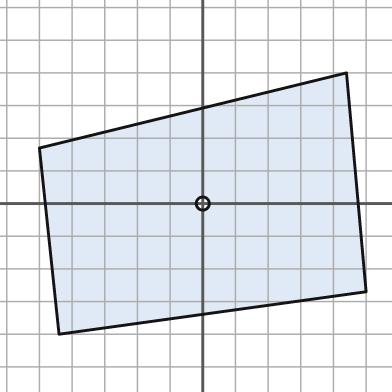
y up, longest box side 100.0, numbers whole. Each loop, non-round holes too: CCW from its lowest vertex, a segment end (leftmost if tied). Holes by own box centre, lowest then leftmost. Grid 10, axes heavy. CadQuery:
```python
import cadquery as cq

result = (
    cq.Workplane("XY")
    .moveTo(-44.0, -40.0)
    .lineTo(50.0, -27.0)
    .lineTo(44.0, 40.0)
    .lineTo(-50.0, 17.0)
    .close()
    .moveTo(0.0, 0.0)
    .circle(2.0)
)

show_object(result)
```